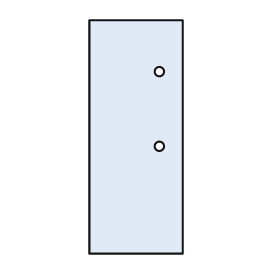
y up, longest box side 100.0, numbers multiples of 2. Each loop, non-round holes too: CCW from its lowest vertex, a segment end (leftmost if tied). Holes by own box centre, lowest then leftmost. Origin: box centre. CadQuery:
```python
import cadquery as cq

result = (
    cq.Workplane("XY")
    .moveTo(-20.0, -50.0)
    .lineTo(20.0, -50.0)
    .lineTo(20.0, 50.0)
    .lineTo(-20.0, 50.0)
    .close()
    .moveTo(10.0, -4.0)
    .circle(2.0)
    .moveTo(10.0, 28.0)
    .circle(2.0)
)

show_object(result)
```